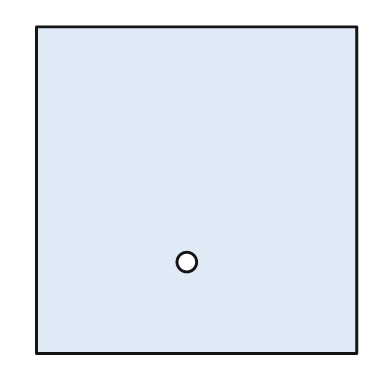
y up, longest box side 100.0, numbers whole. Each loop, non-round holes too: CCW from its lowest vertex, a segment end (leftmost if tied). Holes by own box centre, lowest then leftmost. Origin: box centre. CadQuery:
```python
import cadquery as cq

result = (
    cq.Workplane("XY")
    .moveTo(-49.0, -50.0)
    .lineTo(49.0, -50.0)
    .lineTo(49.0, 50.0)
    .lineTo(-49.0, 50.0)
    .close()
    .moveTo(-3.0, -22.0)
    .circle(3.0)
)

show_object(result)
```